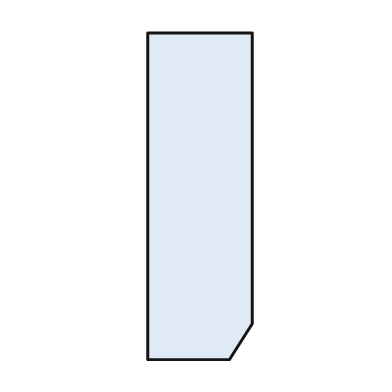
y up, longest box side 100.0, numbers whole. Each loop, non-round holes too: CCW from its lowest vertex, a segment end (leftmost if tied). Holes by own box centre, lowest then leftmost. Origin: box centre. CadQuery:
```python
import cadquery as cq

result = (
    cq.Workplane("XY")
    .moveTo(-16.0, -50.0)
    .lineTo(9.0, -50.0)
    .lineTo(16.0, -39.0)
    .lineTo(16.0, 50.0)
    .lineTo(-16.0, 50.0)
    .close()
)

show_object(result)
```